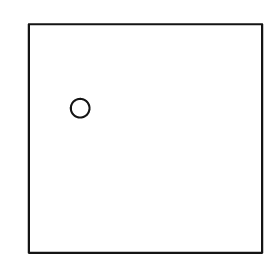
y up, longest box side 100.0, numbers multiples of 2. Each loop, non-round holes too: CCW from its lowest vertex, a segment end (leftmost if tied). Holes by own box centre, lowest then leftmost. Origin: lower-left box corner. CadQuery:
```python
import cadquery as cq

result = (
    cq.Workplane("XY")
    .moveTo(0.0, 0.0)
    .lineTo(100.0, 0.0)
    .lineTo(100.0, 98.0)
    .lineTo(0.0, 98.0)
    .close()
    .moveTo(22.0, 62.0)
    .circle(4.0)
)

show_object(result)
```